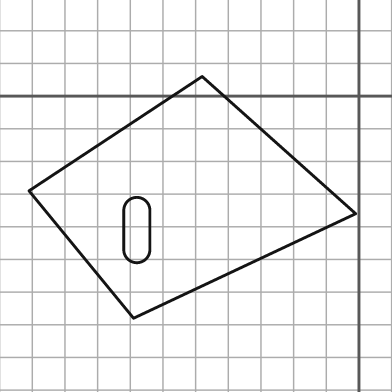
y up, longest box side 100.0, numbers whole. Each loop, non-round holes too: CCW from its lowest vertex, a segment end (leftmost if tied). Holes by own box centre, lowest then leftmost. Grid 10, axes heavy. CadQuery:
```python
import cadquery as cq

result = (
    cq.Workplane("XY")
    .moveTo(-69.0, -68.0)
    .lineTo(-1.0, -36.0)
    .lineTo(-48.0, 6.0)
    .lineTo(-101.0, -29.0)
    .close()
    .moveTo(-72.0, -47.0)
    .threePointArc((-68.0, -51.0), (-64.0, -47.0))
    .lineTo(-64.0, -35.0)
    .threePointArc((-68.0, -31.0), (-72.0, -35.0))
    .close()
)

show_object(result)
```